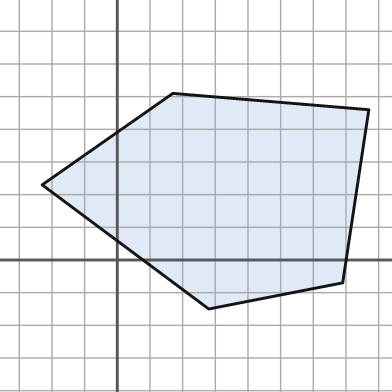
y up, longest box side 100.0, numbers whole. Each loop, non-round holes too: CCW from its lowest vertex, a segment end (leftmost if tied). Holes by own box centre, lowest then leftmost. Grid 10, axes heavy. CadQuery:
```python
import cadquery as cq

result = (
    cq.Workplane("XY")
    .moveTo(28.0, -15.0)
    .lineTo(69.0, -7.0)
    .lineTo(77.0, 46.0)
    .lineTo(17.0, 51.0)
    .lineTo(-23.0, 23.0)
    .close()
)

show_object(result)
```